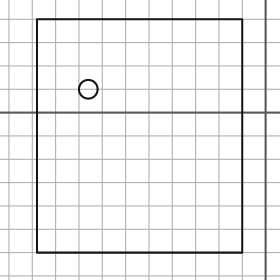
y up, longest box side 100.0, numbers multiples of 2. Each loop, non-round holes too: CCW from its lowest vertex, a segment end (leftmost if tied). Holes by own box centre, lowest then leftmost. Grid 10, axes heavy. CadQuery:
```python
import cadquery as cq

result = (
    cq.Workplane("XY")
    .moveTo(-98.0, -60.0)
    .lineTo(-10.0, -60.0)
    .lineTo(-10.0, 40.0)
    .lineTo(-98.0, 40.0)
    .close()
    .moveTo(-76.0, 10.0)
    .circle(4.0)
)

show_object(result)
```